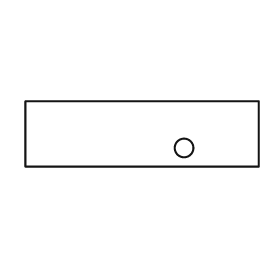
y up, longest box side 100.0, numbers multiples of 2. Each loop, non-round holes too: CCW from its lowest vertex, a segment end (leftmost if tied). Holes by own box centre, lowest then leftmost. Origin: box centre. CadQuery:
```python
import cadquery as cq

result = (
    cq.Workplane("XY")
    .moveTo(-50.0, -14.0)
    .lineTo(50.0, -14.0)
    .lineTo(50.0, 14.0)
    .lineTo(-50.0, 14.0)
    .close()
    .moveTo(18.0, -6.0)
    .circle(4.0)
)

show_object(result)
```